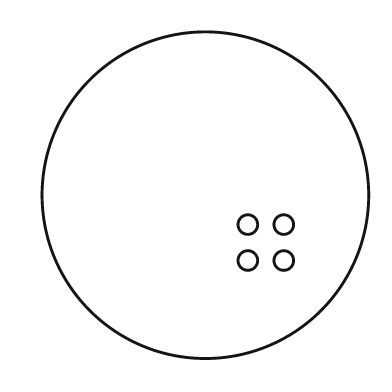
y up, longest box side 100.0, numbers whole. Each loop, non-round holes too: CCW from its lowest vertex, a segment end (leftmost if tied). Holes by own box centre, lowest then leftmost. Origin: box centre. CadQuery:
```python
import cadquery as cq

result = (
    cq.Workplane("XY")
    .moveTo(0.0, 0.0)
    .circle(50.0)
    .moveTo(13.0, -20.0)
    .circle(3.0)
    .moveTo(24.0, -20.0)
    .circle(3.0)
    .moveTo(13.0, -9.0)
    .circle(3.0)
    .moveTo(24.0, -9.0)
    .circle(3.0)
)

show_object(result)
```